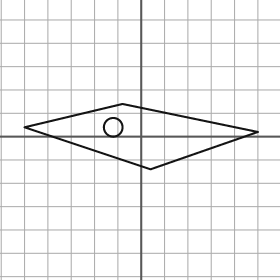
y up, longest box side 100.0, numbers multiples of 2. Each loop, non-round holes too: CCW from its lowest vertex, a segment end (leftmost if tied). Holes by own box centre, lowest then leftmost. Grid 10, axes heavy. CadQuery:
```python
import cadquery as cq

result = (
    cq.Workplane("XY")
    .moveTo(4.0, -14.0)
    .lineTo(50.0, 2.0)
    .lineTo(-8.0, 14.0)
    .lineTo(-50.0, 4.0)
    .close()
    .moveTo(-12.0, 4.0)
    .circle(4.0)
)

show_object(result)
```